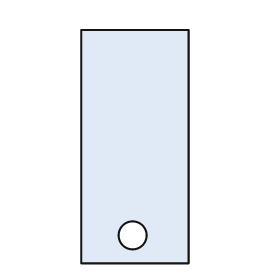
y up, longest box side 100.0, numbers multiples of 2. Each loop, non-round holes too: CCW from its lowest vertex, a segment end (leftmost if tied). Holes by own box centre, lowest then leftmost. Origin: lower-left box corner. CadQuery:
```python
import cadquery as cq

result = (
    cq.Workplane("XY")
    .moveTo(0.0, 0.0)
    .lineTo(46.0, 0.0)
    .lineTo(46.0, 100.0)
    .lineTo(0.0, 100.0)
    .close()
    .moveTo(22.0, 12.0)
    .circle(6.0)
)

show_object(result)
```